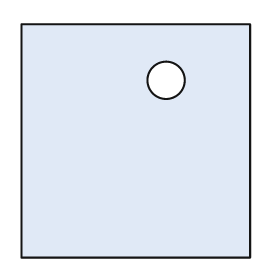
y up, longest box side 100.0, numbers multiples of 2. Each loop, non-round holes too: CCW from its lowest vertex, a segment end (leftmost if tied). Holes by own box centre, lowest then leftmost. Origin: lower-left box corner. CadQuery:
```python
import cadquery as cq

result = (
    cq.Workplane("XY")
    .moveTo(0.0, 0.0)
    .lineTo(98.0, 0.0)
    .lineTo(98.0, 100.0)
    .lineTo(0.0, 100.0)
    .close()
    .moveTo(62.0, 76.0)
    .circle(8.0)
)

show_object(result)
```